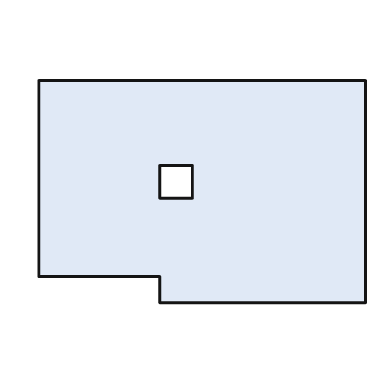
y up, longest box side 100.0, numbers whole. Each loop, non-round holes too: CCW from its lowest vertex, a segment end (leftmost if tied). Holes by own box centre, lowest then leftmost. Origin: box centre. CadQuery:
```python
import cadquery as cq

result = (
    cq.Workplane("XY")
    .moveTo(-13.0, -34.0)
    .lineTo(50.0, -34.0)
    .lineTo(50.0, 34.0)
    .lineTo(-50.0, 34.0)
    .lineTo(-50.0, -26.0)
    .lineTo(-13.0, -26.0)
    .close()
    .moveTo(-13.0, -2.0)
    .lineTo(-3.0, -2.0)
    .lineTo(-3.0, 8.0)
    .lineTo(-13.0, 8.0)
    .close()
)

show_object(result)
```